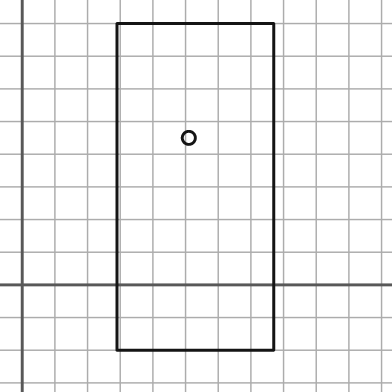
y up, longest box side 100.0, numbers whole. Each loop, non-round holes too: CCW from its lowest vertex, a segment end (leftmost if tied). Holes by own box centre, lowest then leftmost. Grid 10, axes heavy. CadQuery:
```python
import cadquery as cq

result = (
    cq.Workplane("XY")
    .moveTo(29.0, -20.0)
    .lineTo(77.0, -20.0)
    .lineTo(77.0, 80.0)
    .lineTo(29.0, 80.0)
    .close()
    .moveTo(51.0, 45.0)
    .circle(2.0)
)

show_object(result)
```